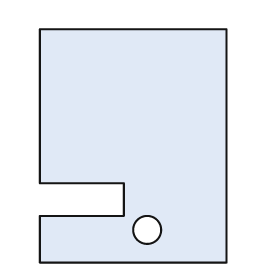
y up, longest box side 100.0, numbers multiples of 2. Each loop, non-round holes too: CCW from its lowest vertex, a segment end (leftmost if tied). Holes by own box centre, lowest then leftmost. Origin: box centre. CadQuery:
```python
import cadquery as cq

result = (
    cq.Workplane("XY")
    .moveTo(-40.0, -50.0)
    .lineTo(40.0, -50.0)
    .lineTo(40.0, 50.0)
    .lineTo(-40.0, 50.0)
    .lineTo(-40.0, -16.0)
    .lineTo(-4.0, -16.0)
    .lineTo(-4.0, -30.0)
    .lineTo(-40.0, -30.0)
    .close()
    .moveTo(6.0, -36.0)
    .circle(6.0)
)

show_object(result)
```